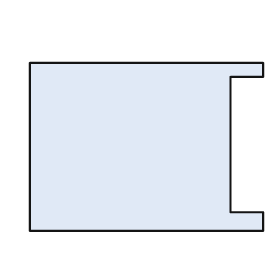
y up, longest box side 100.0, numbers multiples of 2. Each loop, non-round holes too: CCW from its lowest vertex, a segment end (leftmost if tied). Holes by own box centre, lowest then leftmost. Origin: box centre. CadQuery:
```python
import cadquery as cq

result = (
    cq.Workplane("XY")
    .moveTo(-50.0, -36.0)
    .lineTo(50.0, -36.0)
    .lineTo(50.0, -28.0)
    .lineTo(36.0, -28.0)
    .lineTo(36.0, 30.0)
    .lineTo(50.0, 30.0)
    .lineTo(50.0, 36.0)
    .lineTo(-50.0, 36.0)
    .close()
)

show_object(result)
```